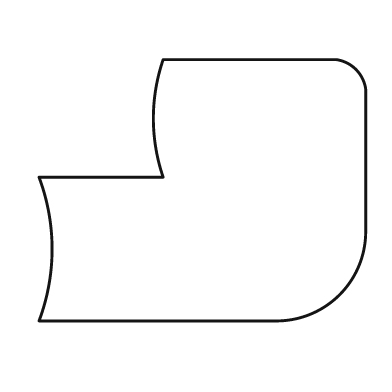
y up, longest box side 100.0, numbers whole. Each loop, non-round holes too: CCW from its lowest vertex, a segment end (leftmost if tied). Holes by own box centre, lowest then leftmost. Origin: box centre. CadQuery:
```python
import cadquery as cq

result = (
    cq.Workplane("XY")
    .moveTo(-50.0, -40.0)
    .lineTo(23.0, -40.0)
    .threePointArc((42.0, -32.0), (50.0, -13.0))
    .lineTo(50.0, 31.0)
    .threePointArc((47.0, 37.0), (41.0, 40.0))
    .lineTo(-12.0, 40.0)
    .threePointArc((-15.0, 22.0), (-12.0, 4.0))
    .lineTo(-50.0, 4.0)
    .threePointArc((-46.0, -18.0), (-50.0, -40.0))
    .close()
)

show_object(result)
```